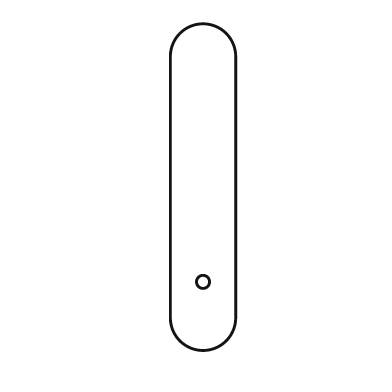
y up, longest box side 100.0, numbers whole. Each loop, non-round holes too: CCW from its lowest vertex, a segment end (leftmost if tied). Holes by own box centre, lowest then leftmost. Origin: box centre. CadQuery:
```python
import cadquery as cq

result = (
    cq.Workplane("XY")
    .moveTo(-10.0, -40.0)
    .threePointArc((0.0, -50.0), (10.0, -40.0))
    .lineTo(10.0, 40.0)
    .threePointArc((0.0, 50.0), (-10.0, 40.0))
    .close()
    .moveTo(0.0, -29.0)
    .circle(2.0)
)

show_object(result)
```